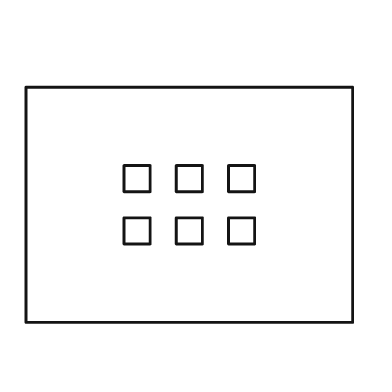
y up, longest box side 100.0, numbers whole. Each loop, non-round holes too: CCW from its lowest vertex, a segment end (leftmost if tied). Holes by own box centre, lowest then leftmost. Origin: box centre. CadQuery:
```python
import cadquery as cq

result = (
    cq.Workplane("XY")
    .moveTo(-50.0, -36.0)
    .lineTo(50.0, -36.0)
    .lineTo(50.0, 36.0)
    .lineTo(-50.0, 36.0)
    .close()
    .moveTo(-20.0, -12.0)
    .lineTo(-12.0, -12.0)
    .lineTo(-12.0, -4.0)
    .lineTo(-20.0, -4.0)
    .close()
    .moveTo(-4.0, -12.0)
    .lineTo(4.0, -12.0)
    .lineTo(4.0, -4.0)
    .lineTo(-4.0, -4.0)
    .close()
    .moveTo(12.0, -12.0)
    .lineTo(20.0, -12.0)
    .lineTo(20.0, -4.0)
    .lineTo(12.0, -4.0)
    .close()
    .moveTo(-20.0, 4.0)
    .lineTo(-12.0, 4.0)
    .lineTo(-12.0, 12.0)
    .lineTo(-20.0, 12.0)
    .close()
    .moveTo(-4.0, 4.0)
    .lineTo(4.0, 4.0)
    .lineTo(4.0, 12.0)
    .lineTo(-4.0, 12.0)
    .close()
    .moveTo(12.0, 4.0)
    .lineTo(20.0, 4.0)
    .lineTo(20.0, 12.0)
    .lineTo(12.0, 12.0)
    .close()
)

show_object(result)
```